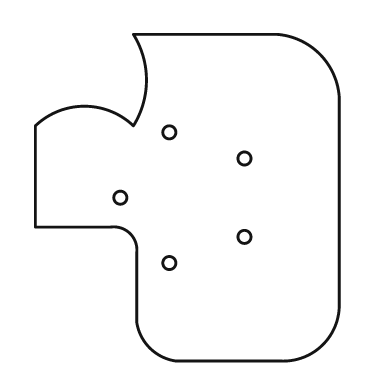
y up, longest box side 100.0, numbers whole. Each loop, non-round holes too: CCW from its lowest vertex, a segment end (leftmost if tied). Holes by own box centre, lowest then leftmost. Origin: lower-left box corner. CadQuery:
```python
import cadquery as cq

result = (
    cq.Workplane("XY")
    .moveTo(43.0, 0.0)
    .lineTo(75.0, 0.0)
    .threePointArc((88.0, 5.0), (93.0, 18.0))
    .lineTo(93.0, 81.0)
    .threePointArc((87.0, 94.0), (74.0, 100.0))
    .lineTo(30.0, 100.0)
    .threePointArc((34.0, 86.0), (30.0, 72.0))
    .threePointArc((15.0, 78.0), (0.0, 72.0))
    .lineTo(0.0, 41.0)
    .lineTo(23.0, 41.0)
    .threePointArc((29.0, 39.0), (31.0, 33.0))
    .lineTo(31.0, 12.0)
    .threePointArc((35.0, 4.0), (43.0, 0.0))
    .close()
    .moveTo(41.0, 30.0)
    .circle(2.0)
    .moveTo(64.0, 38.0)
    .circle(2.0)
    .moveTo(26.0, 50.0)
    .circle(2.0)
    .moveTo(64.0, 62.0)
    .circle(2.0)
    .moveTo(41.0, 70.0)
    .circle(2.0)
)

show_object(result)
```